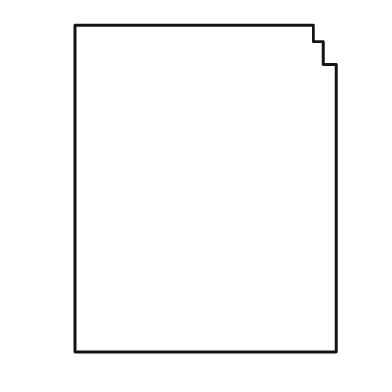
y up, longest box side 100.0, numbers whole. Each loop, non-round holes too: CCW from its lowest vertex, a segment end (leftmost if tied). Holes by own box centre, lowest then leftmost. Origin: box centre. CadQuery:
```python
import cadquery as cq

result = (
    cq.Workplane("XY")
    .moveTo(-40.0, -50.0)
    .lineTo(40.0, -50.0)
    .lineTo(40.0, 38.0)
    .lineTo(36.0, 38.0)
    .lineTo(36.0, 45.0)
    .lineTo(33.0, 45.0)
    .lineTo(33.0, 50.0)
    .lineTo(-40.0, 50.0)
    .close()
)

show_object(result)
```